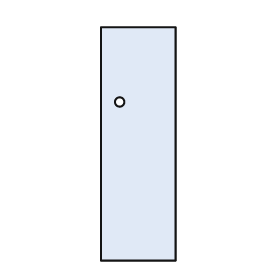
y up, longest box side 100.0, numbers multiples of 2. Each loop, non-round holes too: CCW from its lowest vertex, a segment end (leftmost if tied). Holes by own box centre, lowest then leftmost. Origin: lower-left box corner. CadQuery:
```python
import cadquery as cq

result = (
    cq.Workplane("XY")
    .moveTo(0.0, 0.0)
    .lineTo(32.0, 0.0)
    .lineTo(32.0, 100.0)
    .lineTo(0.0, 100.0)
    .close()
    .moveTo(8.0, 68.0)
    .circle(2.0)
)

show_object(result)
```